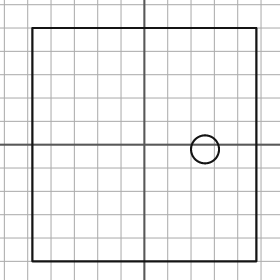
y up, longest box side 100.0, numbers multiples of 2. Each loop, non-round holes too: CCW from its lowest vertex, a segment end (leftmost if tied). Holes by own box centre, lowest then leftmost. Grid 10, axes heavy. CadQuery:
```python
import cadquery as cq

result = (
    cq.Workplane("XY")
    .moveTo(-48.0, -50.0)
    .lineTo(48.0, -50.0)
    .lineTo(48.0, 50.0)
    .lineTo(-48.0, 50.0)
    .close()
    .moveTo(26.0, -2.0)
    .circle(6.0)
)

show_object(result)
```